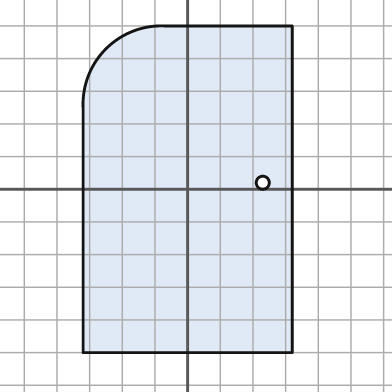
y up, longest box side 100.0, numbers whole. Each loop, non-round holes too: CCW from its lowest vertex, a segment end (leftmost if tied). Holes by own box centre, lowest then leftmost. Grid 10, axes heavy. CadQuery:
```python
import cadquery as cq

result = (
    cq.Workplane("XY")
    .moveTo(-32.0, -50.0)
    .lineTo(32.0, -50.0)
    .lineTo(32.0, 50.0)
    .lineTo(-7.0, 50.0)
    .threePointArc((-25.0, 43.0), (-32.0, 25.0))
    .close()
    .moveTo(23.0, 2.0)
    .circle(2.0)
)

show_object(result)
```